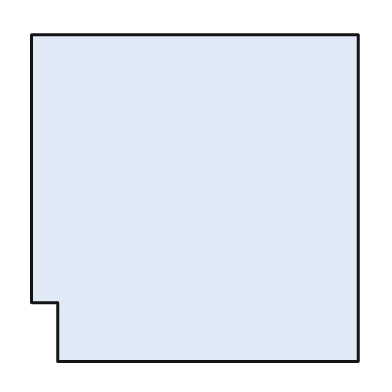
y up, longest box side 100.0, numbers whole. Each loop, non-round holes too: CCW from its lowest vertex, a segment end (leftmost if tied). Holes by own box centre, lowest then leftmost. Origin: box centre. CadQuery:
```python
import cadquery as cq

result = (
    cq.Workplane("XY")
    .moveTo(-42.0, -50.0)
    .lineTo(50.0, -50.0)
    .lineTo(50.0, 50.0)
    .lineTo(-50.0, 50.0)
    .lineTo(-50.0, -32.0)
    .lineTo(-42.0, -32.0)
    .close()
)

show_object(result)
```